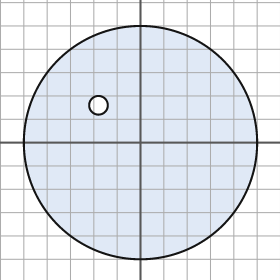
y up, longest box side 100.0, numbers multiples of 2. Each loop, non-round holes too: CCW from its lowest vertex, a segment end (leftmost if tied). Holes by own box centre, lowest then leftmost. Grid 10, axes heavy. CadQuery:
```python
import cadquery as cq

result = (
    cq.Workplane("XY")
    .moveTo(0.0, 0.0)
    .circle(50.0)
    .moveTo(-18.0, 16.0)
    .circle(4.0)
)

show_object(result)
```